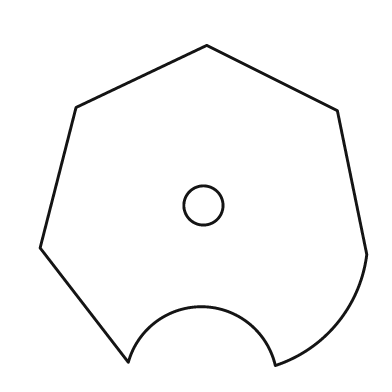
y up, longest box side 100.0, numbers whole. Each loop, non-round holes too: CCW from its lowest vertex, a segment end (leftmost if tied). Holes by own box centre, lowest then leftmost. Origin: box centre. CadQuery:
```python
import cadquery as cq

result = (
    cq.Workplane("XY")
    .moveTo(22.0, -49.0)
    .threePointArc((41.0, -36.0), (50.0, -15.0))
    .lineTo(41.0, 29.0)
    .lineTo(1.0, 49.0)
    .lineTo(-39.0, 30.0)
    .lineTo(-50.0, -13.0)
    .lineTo(-23.0, -48.0)
    .threePointArc((0.0, -31.0), (22.0, -49.0))
    .close()
    .moveTo(0.0, 0.0)
    .circle(6.0)
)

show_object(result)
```